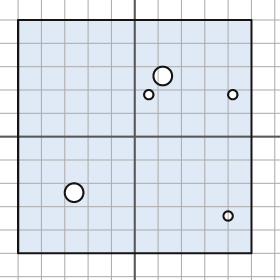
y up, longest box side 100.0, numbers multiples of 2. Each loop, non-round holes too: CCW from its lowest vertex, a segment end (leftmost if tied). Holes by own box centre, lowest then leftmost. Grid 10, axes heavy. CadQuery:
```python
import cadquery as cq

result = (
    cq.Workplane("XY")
    .moveTo(-50.0, -50.0)
    .lineTo(50.0, -50.0)
    .lineTo(50.0, 50.0)
    .lineTo(-50.0, 50.0)
    .close()
    .moveTo(40.0, -34.0)
    .circle(2.0)
    .moveTo(-26.0, -24.0)
    .circle(4.0)
    .moveTo(6.0, 18.0)
    .circle(2.0)
    .moveTo(42.0, 18.0)
    .circle(2.0)
    .moveTo(12.0, 26.0)
    .circle(4.0)
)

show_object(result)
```